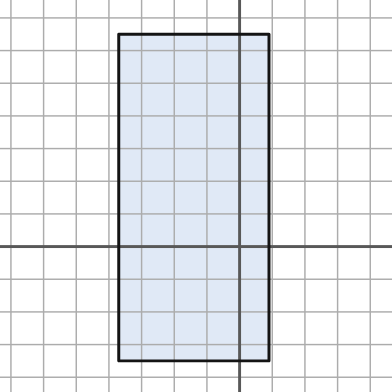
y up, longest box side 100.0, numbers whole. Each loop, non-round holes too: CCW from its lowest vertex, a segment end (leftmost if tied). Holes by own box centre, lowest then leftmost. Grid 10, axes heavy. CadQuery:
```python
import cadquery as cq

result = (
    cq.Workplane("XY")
    .moveTo(-37.0, -35.0)
    .lineTo(9.0, -35.0)
    .lineTo(9.0, 65.0)
    .lineTo(-37.0, 65.0)
    .close()
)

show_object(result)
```